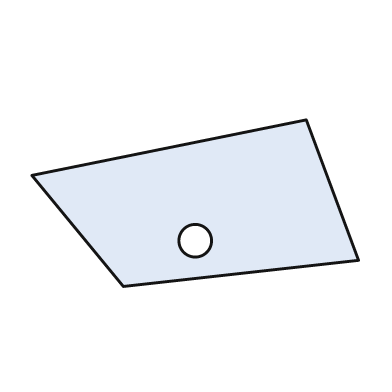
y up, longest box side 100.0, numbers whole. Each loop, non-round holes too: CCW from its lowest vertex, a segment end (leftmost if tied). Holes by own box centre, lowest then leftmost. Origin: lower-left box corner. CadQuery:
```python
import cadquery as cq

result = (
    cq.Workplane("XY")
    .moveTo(28.0, 0.0)
    .lineTo(100.0, 8.0)
    .lineTo(84.0, 51.0)
    .lineTo(0.0, 34.0)
    .close()
    .moveTo(50.0, 14.0)
    .circle(5.0)
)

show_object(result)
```